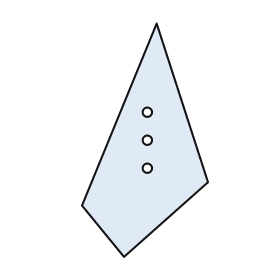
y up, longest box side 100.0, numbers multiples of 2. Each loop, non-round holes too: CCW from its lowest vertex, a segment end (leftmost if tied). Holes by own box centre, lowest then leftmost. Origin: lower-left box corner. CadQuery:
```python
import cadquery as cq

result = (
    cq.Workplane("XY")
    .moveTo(18.0, 0.0)
    .lineTo(54.0, 32.0)
    .lineTo(32.0, 100.0)
    .lineTo(0.0, 22.0)
    .close()
    .moveTo(28.0, 38.0)
    .circle(2.0)
    .moveTo(28.0, 50.0)
    .circle(2.0)
    .moveTo(28.0, 62.0)
    .circle(2.0)
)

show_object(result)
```